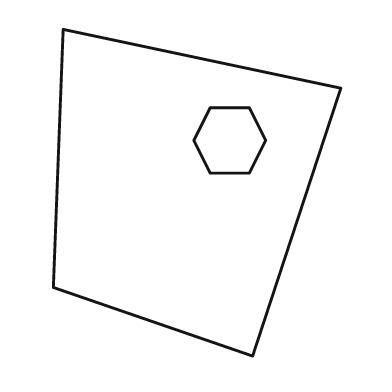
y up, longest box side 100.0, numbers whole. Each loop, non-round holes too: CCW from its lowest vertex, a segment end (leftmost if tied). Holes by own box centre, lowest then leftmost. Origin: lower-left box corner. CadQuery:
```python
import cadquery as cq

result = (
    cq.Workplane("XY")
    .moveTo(61.0, 0.0)
    .lineTo(88.0, 82.0)
    .lineTo(3.0, 100.0)
    .lineTo(0.0, 21.0)
    .close()
    .moveTo(48.0, 56.0)
    .lineTo(60.0, 56.0)
    .lineTo(65.0, 66.0)
    .lineTo(60.0, 76.0)
    .lineTo(48.0, 76.0)
    .lineTo(43.0, 66.0)
    .close()
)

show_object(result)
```